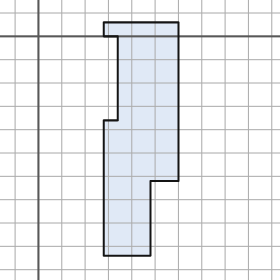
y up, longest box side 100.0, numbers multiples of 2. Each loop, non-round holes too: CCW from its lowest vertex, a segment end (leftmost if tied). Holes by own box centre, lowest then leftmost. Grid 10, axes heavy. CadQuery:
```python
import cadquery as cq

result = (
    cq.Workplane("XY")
    .moveTo(28.0, -94.0)
    .lineTo(48.0, -94.0)
    .lineTo(48.0, -62.0)
    .lineTo(60.0, -62.0)
    .lineTo(60.0, 6.0)
    .lineTo(28.0, 6.0)
    .lineTo(28.0, 0.0)
    .lineTo(34.0, 0.0)
    .lineTo(34.0, -36.0)
    .lineTo(28.0, -36.0)
    .close()
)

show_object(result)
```